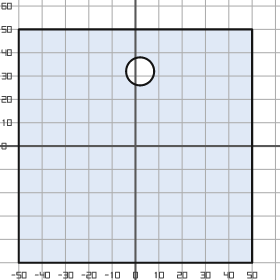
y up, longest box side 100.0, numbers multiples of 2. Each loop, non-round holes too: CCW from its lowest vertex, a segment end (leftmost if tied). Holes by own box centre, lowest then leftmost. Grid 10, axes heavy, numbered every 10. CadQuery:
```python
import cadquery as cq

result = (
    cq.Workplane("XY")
    .moveTo(-50.0, -50.0)
    .lineTo(50.0, -50.0)
    .lineTo(50.0, 50.0)
    .lineTo(-50.0, 50.0)
    .close()
    .moveTo(2.0, 32.0)
    .circle(6.0)
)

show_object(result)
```